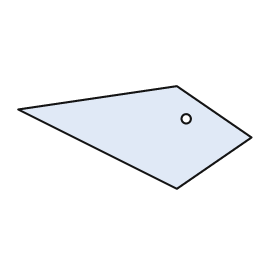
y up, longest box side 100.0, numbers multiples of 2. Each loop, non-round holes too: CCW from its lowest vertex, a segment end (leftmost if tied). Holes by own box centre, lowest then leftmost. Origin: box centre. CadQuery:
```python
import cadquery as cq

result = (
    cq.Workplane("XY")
    .moveTo(18.0, -22.0)
    .lineTo(50.0, 0.0)
    .lineTo(18.0, 22.0)
    .lineTo(-50.0, 12.0)
    .close()
    .moveTo(22.0, 8.0)
    .circle(2.0)
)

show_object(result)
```